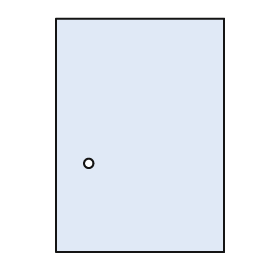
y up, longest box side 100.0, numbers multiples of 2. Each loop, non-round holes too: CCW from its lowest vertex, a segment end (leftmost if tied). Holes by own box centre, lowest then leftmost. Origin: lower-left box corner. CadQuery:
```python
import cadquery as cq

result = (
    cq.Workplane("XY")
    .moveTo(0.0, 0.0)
    .lineTo(72.0, 0.0)
    .lineTo(72.0, 100.0)
    .lineTo(0.0, 100.0)
    .close()
    .moveTo(14.0, 38.0)
    .circle(2.0)
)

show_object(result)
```